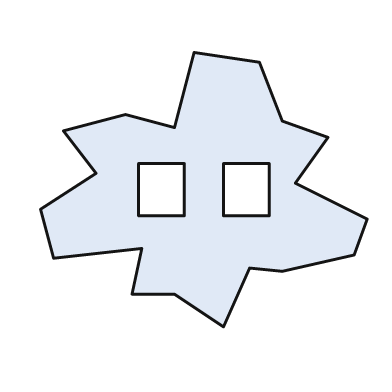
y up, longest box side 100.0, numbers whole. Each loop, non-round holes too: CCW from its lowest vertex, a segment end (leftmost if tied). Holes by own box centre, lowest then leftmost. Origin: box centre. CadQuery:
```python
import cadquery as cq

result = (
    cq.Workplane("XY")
    .moveTo(6.0, -42.0)
    .lineTo(14.0, -24.0)
    .lineTo(24.0, -25.0)
    .lineTo(46.0, -20.0)
    .lineTo(50.0, -9.0)
    .lineTo(28.0, 2.0)
    .lineTo(38.0, 16.0)
    .lineTo(24.0, 21.0)
    .lineTo(17.0, 39.0)
    .lineTo(-3.0, 42.0)
    .lineTo(-9.0, 19.0)
    .lineTo(-24.0, 23.0)
    .lineTo(-43.0, 18.0)
    .lineTo(-33.0, 5.0)
    .lineTo(-50.0, -6.0)
    .lineTo(-46.0, -21.0)
    .lineTo(-19.0, -18.0)
    .lineTo(-22.0, -32.0)
    .lineTo(-9.0, -32.0)
    .close()
    .moveTo(-20.0, -8.0)
    .lineTo(-6.0, -8.0)
    .lineTo(-6.0, 8.0)
    .lineTo(-20.0, 8.0)
    .close()
    .moveTo(6.0, -8.0)
    .lineTo(20.0, -8.0)
    .lineTo(20.0, 8.0)
    .lineTo(6.0, 8.0)
    .close()
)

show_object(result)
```